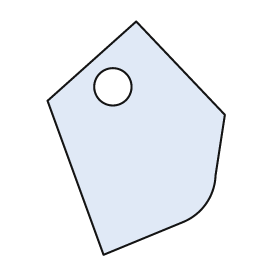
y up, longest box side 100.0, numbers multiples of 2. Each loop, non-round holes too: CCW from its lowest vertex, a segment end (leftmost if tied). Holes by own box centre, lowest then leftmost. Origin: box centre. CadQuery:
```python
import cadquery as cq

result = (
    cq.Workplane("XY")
    .moveTo(-14.0, -50.0)
    .lineTo(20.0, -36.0)
    .threePointArc((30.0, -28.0), (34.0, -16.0))
    .lineTo(38.0, 10.0)
    .lineTo(0.0, 50.0)
    .lineTo(-38.0, 16.0)
    .close()
    .moveTo(-10.0, 22.0)
    .circle(8.0)
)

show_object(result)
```